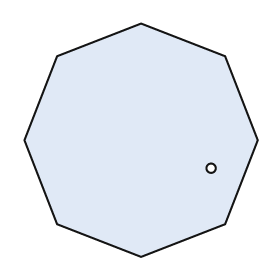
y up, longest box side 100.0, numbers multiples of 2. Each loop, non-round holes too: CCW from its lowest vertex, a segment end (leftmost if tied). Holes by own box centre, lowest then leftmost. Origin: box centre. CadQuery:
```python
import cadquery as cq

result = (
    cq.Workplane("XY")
    .moveTo(0.0, -50.0)
    .lineTo(36.0, -36.0)
    .lineTo(50.0, 0.0)
    .lineTo(36.0, 36.0)
    .lineTo(0.0, 50.0)
    .lineTo(-36.0, 36.0)
    .lineTo(-50.0, 0.0)
    .lineTo(-36.0, -36.0)
    .close()
    .moveTo(30.0, -12.0)
    .circle(2.0)
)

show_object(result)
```